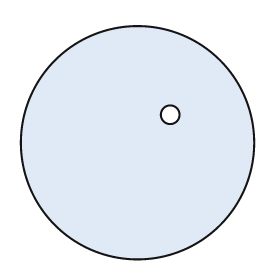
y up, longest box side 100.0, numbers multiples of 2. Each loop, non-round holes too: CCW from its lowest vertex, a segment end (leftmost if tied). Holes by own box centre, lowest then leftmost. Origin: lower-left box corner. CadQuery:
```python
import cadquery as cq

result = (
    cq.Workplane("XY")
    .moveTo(50.0, 50.0)
    .circle(50.0)
    .moveTo(64.0, 62.0)
    .circle(4.0)
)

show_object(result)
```